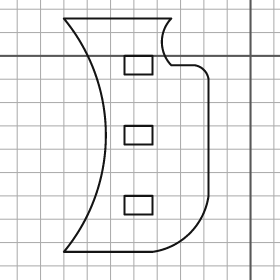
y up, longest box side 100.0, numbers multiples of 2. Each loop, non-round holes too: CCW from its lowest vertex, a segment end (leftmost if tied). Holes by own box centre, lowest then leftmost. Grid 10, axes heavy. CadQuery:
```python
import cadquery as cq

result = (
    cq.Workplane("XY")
    .moveTo(-80.0, -84.0)
    .lineTo(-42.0, -84.0)
    .threePointArc((-26.0, -76.0), (-18.0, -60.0))
    .lineTo(-18.0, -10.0)
    .threePointArc((-20.0, -6.0), (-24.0, -4.0))
    .lineTo(-34.0, -4.0)
    .threePointArc((-38.0, 6.0), (-34.0, 16.0))
    .lineTo(-80.0, 16.0)
    .threePointArc((-62.0, -34.0), (-80.0, -84.0))
    .close()
    .moveTo(-54.0, -68.0)
    .lineTo(-42.0, -68.0)
    .lineTo(-42.0, -60.0)
    .lineTo(-54.0, -60.0)
    .close()
    .moveTo(-54.0, -38.0)
    .lineTo(-42.0, -38.0)
    .lineTo(-42.0, -30.0)
    .lineTo(-54.0, -30.0)
    .close()
    .moveTo(-54.0, -8.0)
    .lineTo(-42.0, -8.0)
    .lineTo(-42.0, 0.0)
    .lineTo(-54.0, 0.0)
    .close()
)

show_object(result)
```